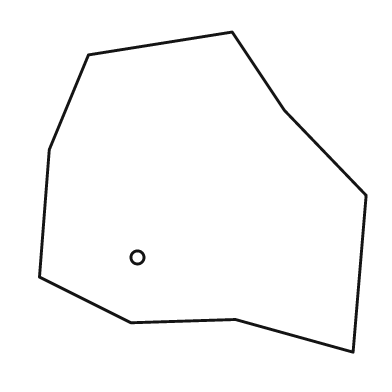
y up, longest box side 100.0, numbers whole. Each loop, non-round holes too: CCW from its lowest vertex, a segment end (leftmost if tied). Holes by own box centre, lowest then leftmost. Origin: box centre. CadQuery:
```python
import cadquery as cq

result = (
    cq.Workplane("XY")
    .moveTo(46.0, -49.0)
    .lineTo(50.0, -1.0)
    .lineTo(25.0, 25.0)
    .lineTo(9.0, 49.0)
    .lineTo(-35.0, 42.0)
    .lineTo(-47.0, 13.0)
    .lineTo(-50.0, -26.0)
    .lineTo(-22.0, -40.0)
    .lineTo(10.0, -39.0)
    .close()
    .moveTo(-20.0, -20.0)
    .circle(2.0)
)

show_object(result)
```